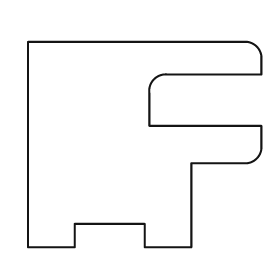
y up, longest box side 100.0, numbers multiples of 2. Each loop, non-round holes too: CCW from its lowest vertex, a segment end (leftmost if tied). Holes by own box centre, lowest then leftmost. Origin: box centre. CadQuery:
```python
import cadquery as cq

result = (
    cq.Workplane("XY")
    .moveTo(-50.0, -44.0)
    .lineTo(-30.0, -44.0)
    .lineTo(-30.0, -34.0)
    .lineTo(0.0, -34.0)
    .lineTo(0.0, -44.0)
    .lineTo(20.0, -44.0)
    .lineTo(20.0, -8.0)
    .lineTo(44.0, -8.0)
    .threePointArc((48.0, -6.0), (50.0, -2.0))
    .lineTo(50.0, 8.0)
    .lineTo(2.0, 8.0)
    .lineTo(2.0, 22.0)
    .threePointArc((4.0, 28.0), (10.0, 30.0))
    .lineTo(50.0, 30.0)
    .lineTo(50.0, 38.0)
    .threePointArc((48.0, 42.0), (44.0, 44.0))
    .lineTo(-50.0, 44.0)
    .close()
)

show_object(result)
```